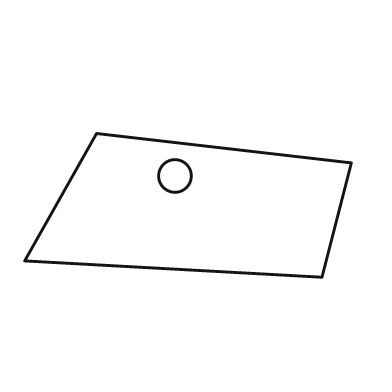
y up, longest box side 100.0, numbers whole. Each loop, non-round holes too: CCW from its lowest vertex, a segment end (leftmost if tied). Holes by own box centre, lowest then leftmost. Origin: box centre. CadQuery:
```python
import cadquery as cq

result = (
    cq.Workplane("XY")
    .moveTo(41.0, -22.0)
    .lineTo(50.0, 13.0)
    .lineTo(-28.0, 22.0)
    .lineTo(-50.0, -17.0)
    .close()
    .moveTo(-4.0, 9.0)
    .circle(5.0)
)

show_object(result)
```